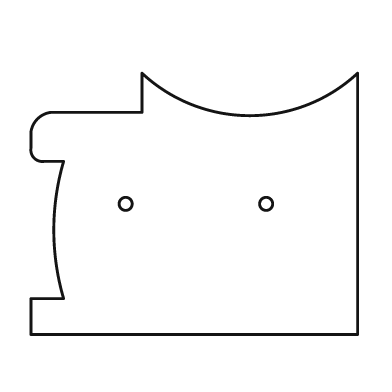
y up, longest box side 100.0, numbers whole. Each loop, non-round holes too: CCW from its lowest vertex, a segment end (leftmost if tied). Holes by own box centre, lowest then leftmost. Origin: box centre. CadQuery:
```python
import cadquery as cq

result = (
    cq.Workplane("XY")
    .moveTo(-50.0, -40.0)
    .lineTo(50.0, -40.0)
    .lineTo(50.0, 40.0)
    .threePointArc((17.0, 27.0), (-16.0, 40.0))
    .lineTo(-16.0, 28.0)
    .lineTo(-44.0, 28.0)
    .threePointArc((-48.0, 26.0), (-50.0, 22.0))
    .lineTo(-50.0, 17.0)
    .threePointArc((-49.0, 14.0), (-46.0, 13.0))
    .lineTo(-40.0, 13.0)
    .threePointArc((-43.0, -8.0), (-40.0, -29.0))
    .lineTo(-50.0, -29.0)
    .close()
    .moveTo(-21.0, 0.0)
    .circle(2.0)
    .moveTo(22.0, 0.0)
    .circle(2.0)
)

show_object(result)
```